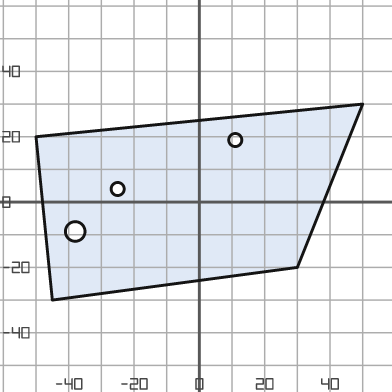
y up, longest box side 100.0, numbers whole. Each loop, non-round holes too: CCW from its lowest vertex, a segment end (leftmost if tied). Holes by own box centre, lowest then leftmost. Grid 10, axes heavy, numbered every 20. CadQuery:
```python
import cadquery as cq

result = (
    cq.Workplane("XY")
    .moveTo(-45.0, -30.0)
    .lineTo(30.0, -20.0)
    .lineTo(50.0, 30.0)
    .lineTo(-50.0, 20.0)
    .close()
    .moveTo(-38.0, -9.0)
    .circle(3.0)
    .moveTo(-25.0, 4.0)
    .circle(2.0)
    .moveTo(11.0, 19.0)
    .circle(2.0)
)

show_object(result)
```